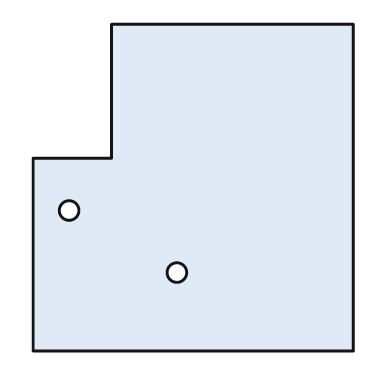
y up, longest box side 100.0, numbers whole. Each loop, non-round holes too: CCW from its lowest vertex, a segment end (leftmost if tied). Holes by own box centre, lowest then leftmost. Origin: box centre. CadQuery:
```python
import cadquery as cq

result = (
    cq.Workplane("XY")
    .moveTo(-49.0, -50.0)
    .lineTo(49.0, -50.0)
    .lineTo(49.0, 50.0)
    .lineTo(-25.0, 50.0)
    .lineTo(-25.0, 9.0)
    .lineTo(-49.0, 9.0)
    .close()
    .moveTo(-5.0, -26.0)
    .circle(3.0)
    .moveTo(-38.0, -7.0)
    .circle(3.0)
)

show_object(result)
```